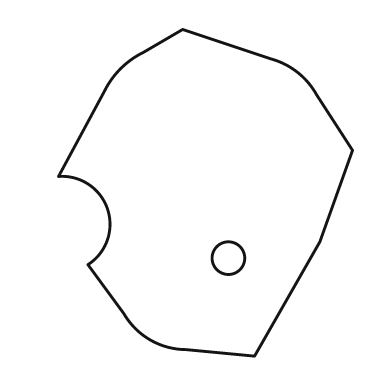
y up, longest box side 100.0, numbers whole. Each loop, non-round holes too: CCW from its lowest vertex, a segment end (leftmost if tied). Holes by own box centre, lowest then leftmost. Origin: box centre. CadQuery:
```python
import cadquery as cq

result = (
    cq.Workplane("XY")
    .moveTo(15.0, -50.0)
    .lineTo(35.0, -15.0)
    .lineTo(45.0, 13.0)
    .lineTo(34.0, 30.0)
    .threePointArc((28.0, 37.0), (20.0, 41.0))
    .lineTo(-7.0, 50.0)
    .lineTo(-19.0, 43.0)
    .threePointArc((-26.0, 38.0), (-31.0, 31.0))
    .lineTo(-45.0, 5.0)
    .threePointArc((-30.0, -5.0), (-36.0, -22.0))
    .lineTo(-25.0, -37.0)
    .threePointArc((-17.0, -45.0), (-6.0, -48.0))
    .close()
    .moveTo(7.0, -20.0)
    .circle(5.0)
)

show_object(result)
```